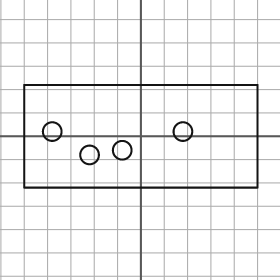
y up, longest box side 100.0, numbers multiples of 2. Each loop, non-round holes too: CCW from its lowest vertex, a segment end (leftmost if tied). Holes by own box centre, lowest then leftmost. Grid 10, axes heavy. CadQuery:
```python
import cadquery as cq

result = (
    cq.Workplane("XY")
    .moveTo(-50.0, -22.0)
    .lineTo(50.0, -22.0)
    .lineTo(50.0, 22.0)
    .lineTo(-50.0, 22.0)
    .close()
    .moveTo(-22.0, -8.0)
    .circle(4.0)
    .moveTo(-8.0, -6.0)
    .circle(4.0)
    .moveTo(-38.0, 2.0)
    .circle(4.0)
    .moveTo(18.0, 2.0)
    .circle(4.0)
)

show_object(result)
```